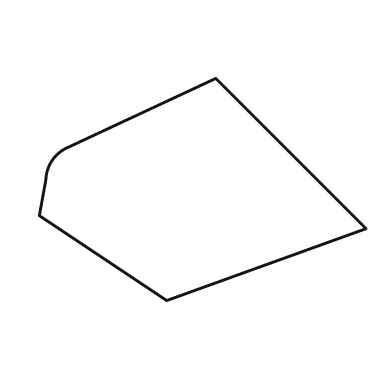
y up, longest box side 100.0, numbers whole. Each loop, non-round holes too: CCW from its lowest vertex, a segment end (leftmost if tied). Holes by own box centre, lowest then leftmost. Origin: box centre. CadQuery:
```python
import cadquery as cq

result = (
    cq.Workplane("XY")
    .moveTo(-11.0, -34.0)
    .lineTo(50.0, -12.0)
    .lineTo(4.0, 34.0)
    .lineTo(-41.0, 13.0)
    .threePointArc((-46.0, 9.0), (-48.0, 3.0))
    .lineTo(-50.0, -8.0)
    .close()
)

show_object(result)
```